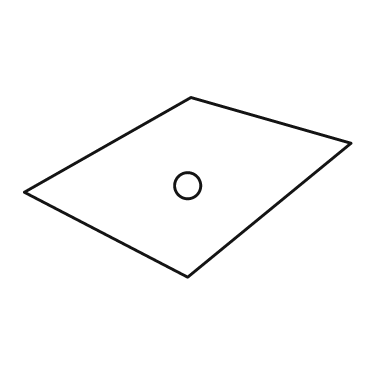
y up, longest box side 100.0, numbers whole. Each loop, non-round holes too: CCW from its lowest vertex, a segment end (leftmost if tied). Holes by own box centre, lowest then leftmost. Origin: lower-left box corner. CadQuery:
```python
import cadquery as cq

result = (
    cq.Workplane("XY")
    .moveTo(50.0, 0.0)
    .lineTo(100.0, 41.0)
    .lineTo(51.0, 55.0)
    .lineTo(0.0, 26.0)
    .close()
    .moveTo(50.0, 28.0)
    .circle(4.0)
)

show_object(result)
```